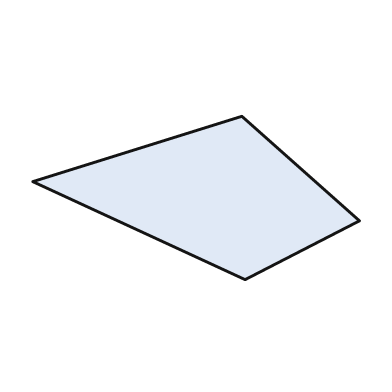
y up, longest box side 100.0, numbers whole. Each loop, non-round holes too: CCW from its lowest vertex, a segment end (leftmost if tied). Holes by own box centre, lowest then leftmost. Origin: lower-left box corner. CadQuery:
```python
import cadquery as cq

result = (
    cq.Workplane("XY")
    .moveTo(65.0, 0.0)
    .lineTo(100.0, 18.0)
    .lineTo(64.0, 50.0)
    .lineTo(0.0, 30.0)
    .close()
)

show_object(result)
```